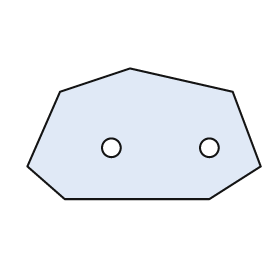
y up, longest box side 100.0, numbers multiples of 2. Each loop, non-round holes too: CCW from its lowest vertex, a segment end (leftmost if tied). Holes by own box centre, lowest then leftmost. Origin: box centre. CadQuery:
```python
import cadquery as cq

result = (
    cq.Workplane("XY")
    .moveTo(-34.0, -28.0)
    .lineTo(28.0, -28.0)
    .lineTo(50.0, -14.0)
    .lineTo(38.0, 18.0)
    .lineTo(-6.0, 28.0)
    .lineTo(-36.0, 18.0)
    .lineTo(-50.0, -14.0)
    .close()
    .moveTo(-14.0, -6.0)
    .circle(4.0)
    .moveTo(28.0, -6.0)
    .circle(4.0)
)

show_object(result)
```